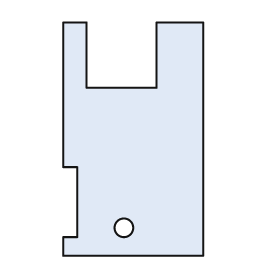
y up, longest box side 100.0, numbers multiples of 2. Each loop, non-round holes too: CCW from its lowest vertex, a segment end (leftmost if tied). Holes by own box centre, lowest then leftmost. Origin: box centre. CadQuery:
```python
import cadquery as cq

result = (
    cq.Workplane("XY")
    .moveTo(-30.0, -50.0)
    .lineTo(30.0, -50.0)
    .lineTo(30.0, 50.0)
    .lineTo(10.0, 50.0)
    .lineTo(10.0, 22.0)
    .lineTo(-20.0, 22.0)
    .lineTo(-20.0, 50.0)
    .lineTo(-30.0, 50.0)
    .lineTo(-30.0, -12.0)
    .lineTo(-24.0, -12.0)
    .lineTo(-24.0, -42.0)
    .lineTo(-30.0, -42.0)
    .close()
    .moveTo(-4.0, -38.0)
    .circle(4.0)
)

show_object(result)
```